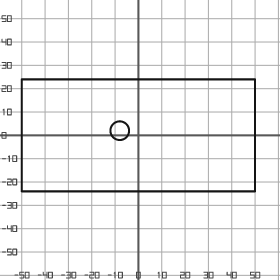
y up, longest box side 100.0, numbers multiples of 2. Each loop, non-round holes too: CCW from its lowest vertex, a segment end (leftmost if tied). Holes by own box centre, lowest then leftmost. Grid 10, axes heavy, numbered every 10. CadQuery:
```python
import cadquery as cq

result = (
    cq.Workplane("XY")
    .moveTo(-50.0, -24.0)
    .lineTo(50.0, -24.0)
    .lineTo(50.0, 24.0)
    .lineTo(-50.0, 24.0)
    .close()
    .moveTo(-8.0, 2.0)
    .circle(4.0)
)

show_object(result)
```